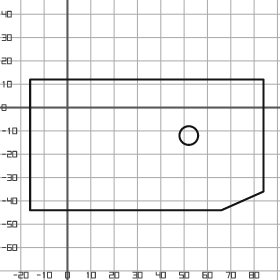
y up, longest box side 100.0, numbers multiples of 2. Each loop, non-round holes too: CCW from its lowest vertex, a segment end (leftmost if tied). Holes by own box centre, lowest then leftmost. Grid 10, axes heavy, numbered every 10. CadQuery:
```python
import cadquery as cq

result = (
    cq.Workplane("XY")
    .moveTo(-16.0, -44.0)
    .lineTo(66.0, -44.0)
    .lineTo(84.0, -36.0)
    .lineTo(84.0, 12.0)
    .lineTo(-16.0, 12.0)
    .close()
    .moveTo(52.0, -12.0)
    .circle(4.0)
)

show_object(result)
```